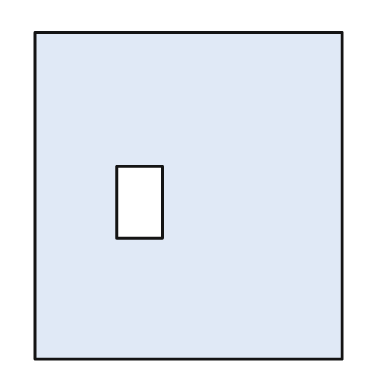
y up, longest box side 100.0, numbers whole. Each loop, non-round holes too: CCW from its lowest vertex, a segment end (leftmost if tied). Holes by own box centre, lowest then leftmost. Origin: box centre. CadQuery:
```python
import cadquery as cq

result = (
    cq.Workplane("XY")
    .moveTo(-47.0, -50.0)
    .lineTo(47.0, -50.0)
    .lineTo(47.0, 50.0)
    .lineTo(-47.0, 50.0)
    .close()
    .moveTo(-22.0, -13.0)
    .lineTo(-8.0, -13.0)
    .lineTo(-8.0, 9.0)
    .lineTo(-22.0, 9.0)
    .close()
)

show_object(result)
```